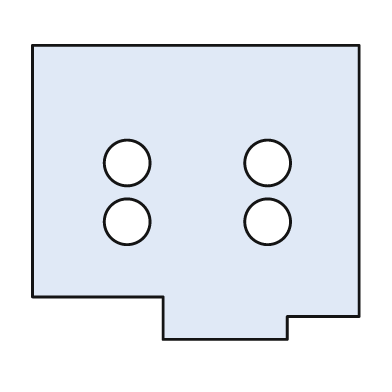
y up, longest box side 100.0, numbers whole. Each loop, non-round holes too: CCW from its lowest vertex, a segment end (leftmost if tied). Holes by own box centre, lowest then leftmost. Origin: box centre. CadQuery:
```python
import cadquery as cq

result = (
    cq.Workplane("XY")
    .moveTo(-10.0, -45.0)
    .lineTo(28.0, -45.0)
    .lineTo(28.0, -38.0)
    .lineTo(50.0, -38.0)
    .lineTo(50.0, 45.0)
    .lineTo(-50.0, 45.0)
    .lineTo(-50.0, -32.0)
    .lineTo(-10.0, -32.0)
    .close()
    .moveTo(-21.0, -9.0)
    .circle(7.0)
    .moveTo(22.0, -9.0)
    .circle(7.0)
    .moveTo(-21.0, 9.0)
    .circle(7.0)
    .moveTo(22.0, 9.0)
    .circle(7.0)
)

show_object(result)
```